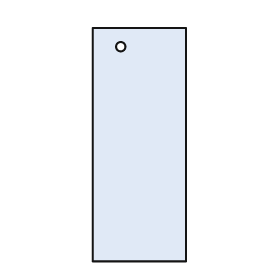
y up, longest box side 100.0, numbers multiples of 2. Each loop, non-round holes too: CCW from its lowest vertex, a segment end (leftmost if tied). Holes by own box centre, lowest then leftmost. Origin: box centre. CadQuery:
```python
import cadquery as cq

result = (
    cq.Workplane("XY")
    .moveTo(-20.0, -50.0)
    .lineTo(20.0, -50.0)
    .lineTo(20.0, 50.0)
    .lineTo(-20.0, 50.0)
    .close()
    .moveTo(-8.0, 42.0)
    .circle(2.0)
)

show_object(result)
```